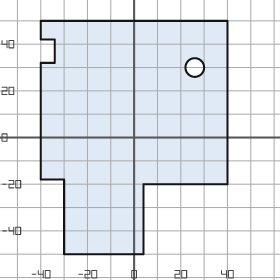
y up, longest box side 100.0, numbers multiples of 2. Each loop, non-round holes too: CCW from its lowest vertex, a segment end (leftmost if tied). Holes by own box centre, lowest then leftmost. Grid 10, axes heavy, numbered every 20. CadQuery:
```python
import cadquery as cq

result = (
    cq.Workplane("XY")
    .moveTo(-30.0, -50.0)
    .lineTo(4.0, -50.0)
    .lineTo(4.0, -20.0)
    .lineTo(40.0, -20.0)
    .lineTo(40.0, 50.0)
    .lineTo(-40.0, 50.0)
    .lineTo(-40.0, 42.0)
    .lineTo(-34.0, 42.0)
    .lineTo(-34.0, 32.0)
    .lineTo(-40.0, 32.0)
    .lineTo(-40.0, -18.0)
    .lineTo(-30.0, -18.0)
    .close()
    .moveTo(26.0, 30.0)
    .circle(4.0)
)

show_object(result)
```